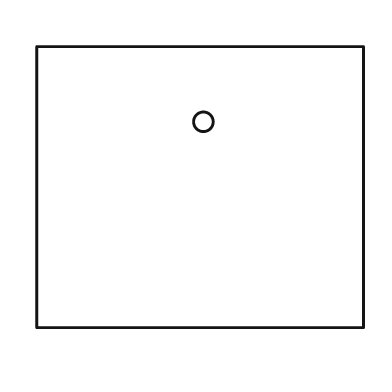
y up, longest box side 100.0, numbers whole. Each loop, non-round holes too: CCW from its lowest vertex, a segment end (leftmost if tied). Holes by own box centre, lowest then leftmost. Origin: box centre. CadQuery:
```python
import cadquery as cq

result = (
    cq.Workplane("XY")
    .moveTo(-50.0, -43.0)
    .lineTo(50.0, -43.0)
    .lineTo(50.0, 43.0)
    .lineTo(-50.0, 43.0)
    .close()
    .moveTo(1.0, 20.0)
    .circle(3.0)
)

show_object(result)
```